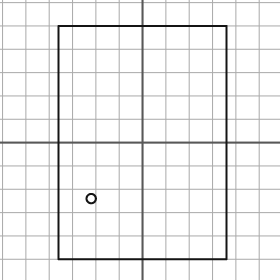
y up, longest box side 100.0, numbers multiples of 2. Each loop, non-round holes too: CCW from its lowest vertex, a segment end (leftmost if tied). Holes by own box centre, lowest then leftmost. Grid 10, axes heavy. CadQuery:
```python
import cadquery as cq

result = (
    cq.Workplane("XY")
    .moveTo(-36.0, -50.0)
    .lineTo(36.0, -50.0)
    .lineTo(36.0, 50.0)
    .lineTo(-36.0, 50.0)
    .close()
    .moveTo(-22.0, -24.0)
    .circle(2.0)
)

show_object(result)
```